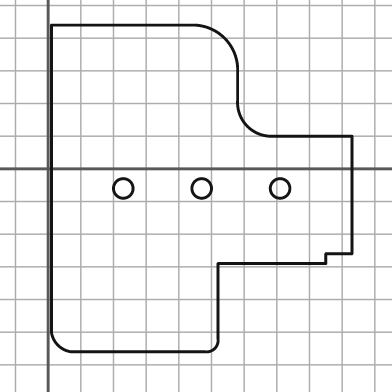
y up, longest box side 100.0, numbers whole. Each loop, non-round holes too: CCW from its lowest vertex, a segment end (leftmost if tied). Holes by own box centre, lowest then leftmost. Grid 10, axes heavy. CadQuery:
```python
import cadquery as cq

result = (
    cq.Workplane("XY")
    .moveTo(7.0, -56.0)
    .lineTo(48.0, -56.0)
    .threePointArc((51.0, -55.0), (52.0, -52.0))
    .lineTo(52.0, -29.0)
    .lineTo(85.0, -29.0)
    .lineTo(85.0, -26.0)
    .lineTo(93.0, -26.0)
    .lineTo(93.0, 10.0)
    .lineTo(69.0, 10.0)
    .threePointArc((61.0, 13.0), (58.0, 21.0))
    .lineTo(58.0, 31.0)
    .threePointArc((54.0, 40.0), (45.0, 44.0))
    .lineTo(1.0, 44.0)
    .lineTo(1.0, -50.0)
    .threePointArc((3.0, -54.0), (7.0, -56.0))
    .close()
    .moveTo(23.0, -6.0)
    .circle(3.0)
    .moveTo(47.0, -6.0)
    .circle(3.0)
    .moveTo(71.0, -6.0)
    .circle(3.0)
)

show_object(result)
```